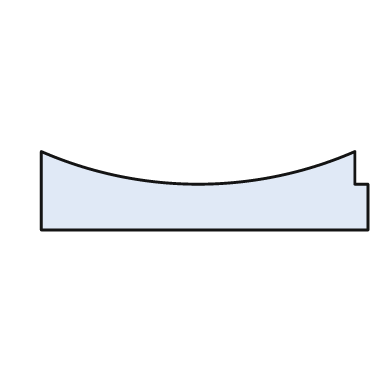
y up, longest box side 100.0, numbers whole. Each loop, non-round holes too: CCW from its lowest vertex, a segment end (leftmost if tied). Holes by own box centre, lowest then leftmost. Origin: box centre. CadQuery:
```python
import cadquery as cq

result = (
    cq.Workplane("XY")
    .moveTo(-50.0, -12.0)
    .lineTo(50.0, -12.0)
    .lineTo(50.0, 2.0)
    .lineTo(46.0, 2.0)
    .lineTo(46.0, 12.0)
    .threePointArc((-2.0, 2.0), (-50.0, 12.0))
    .close()
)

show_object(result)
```